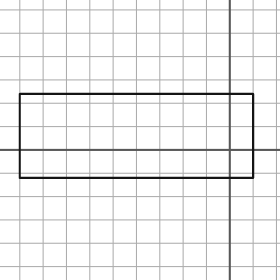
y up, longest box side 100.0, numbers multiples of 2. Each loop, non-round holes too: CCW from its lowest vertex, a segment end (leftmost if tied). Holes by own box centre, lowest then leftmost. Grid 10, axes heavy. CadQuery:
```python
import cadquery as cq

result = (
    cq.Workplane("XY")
    .moveTo(-90.0, -12.0)
    .lineTo(10.0, -12.0)
    .lineTo(10.0, 24.0)
    .lineTo(-90.0, 24.0)
    .close()
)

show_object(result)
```